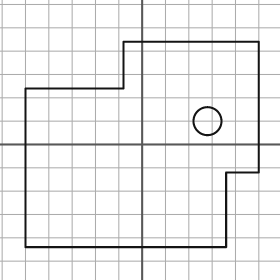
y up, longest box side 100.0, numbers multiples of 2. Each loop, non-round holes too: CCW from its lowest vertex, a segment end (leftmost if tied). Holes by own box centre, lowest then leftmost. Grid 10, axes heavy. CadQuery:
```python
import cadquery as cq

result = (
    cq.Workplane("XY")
    .moveTo(-50.0, -44.0)
    .lineTo(36.0, -44.0)
    .lineTo(36.0, -12.0)
    .lineTo(50.0, -12.0)
    .lineTo(50.0, 44.0)
    .lineTo(-8.0, 44.0)
    .lineTo(-8.0, 24.0)
    .lineTo(-50.0, 24.0)
    .close()
    .moveTo(28.0, 10.0)
    .circle(6.0)
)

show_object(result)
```